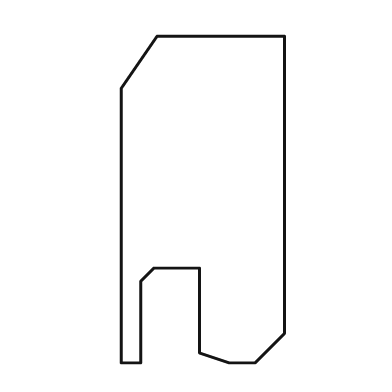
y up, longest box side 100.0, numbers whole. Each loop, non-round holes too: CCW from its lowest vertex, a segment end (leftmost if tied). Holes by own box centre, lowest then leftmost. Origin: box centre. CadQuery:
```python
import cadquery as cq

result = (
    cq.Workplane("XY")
    .moveTo(-25.0, -50.0)
    .lineTo(-19.0, -50.0)
    .lineTo(-19.0, -25.0)
    .lineTo(-15.0, -21.0)
    .lineTo(-1.0, -21.0)
    .lineTo(-1.0, -47.0)
    .lineTo(8.0, -50.0)
    .lineTo(16.0, -50.0)
    .lineTo(25.0, -41.0)
    .lineTo(25.0, 50.0)
    .lineTo(-14.0, 50.0)
    .lineTo(-25.0, 34.0)
    .close()
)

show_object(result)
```